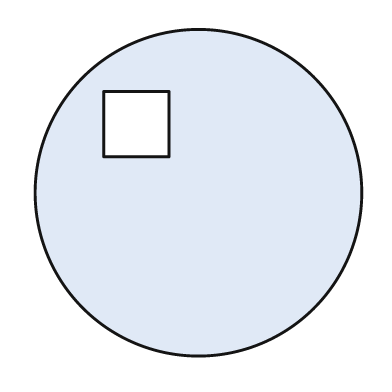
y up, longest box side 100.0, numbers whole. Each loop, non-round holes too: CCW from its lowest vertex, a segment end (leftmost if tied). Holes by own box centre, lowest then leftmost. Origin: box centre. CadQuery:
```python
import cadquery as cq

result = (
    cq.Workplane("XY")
    .moveTo(0.0, 0.0)
    .circle(50.0)
    .moveTo(-29.0, 11.0)
    .lineTo(-9.0, 11.0)
    .lineTo(-9.0, 31.0)
    .lineTo(-29.0, 31.0)
    .close()
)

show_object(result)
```